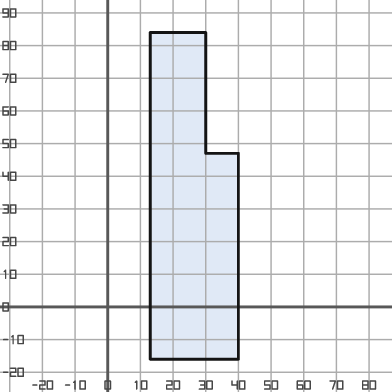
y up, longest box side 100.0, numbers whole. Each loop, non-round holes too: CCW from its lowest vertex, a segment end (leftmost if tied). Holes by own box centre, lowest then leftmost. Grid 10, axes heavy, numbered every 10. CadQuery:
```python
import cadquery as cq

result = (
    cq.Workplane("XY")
    .moveTo(13.0, -16.0)
    .lineTo(40.0, -16.0)
    .lineTo(40.0, 47.0)
    .lineTo(30.0, 47.0)
    .lineTo(30.0, 84.0)
    .lineTo(13.0, 84.0)
    .close()
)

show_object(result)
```